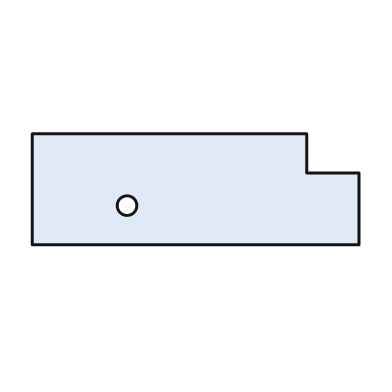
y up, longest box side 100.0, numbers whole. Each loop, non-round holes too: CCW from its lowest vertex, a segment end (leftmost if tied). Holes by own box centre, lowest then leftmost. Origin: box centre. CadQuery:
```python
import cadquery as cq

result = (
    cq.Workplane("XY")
    .moveTo(-50.0, -17.0)
    .lineTo(50.0, -17.0)
    .lineTo(50.0, 5.0)
    .lineTo(34.0, 5.0)
    .lineTo(34.0, 17.0)
    .lineTo(-50.0, 17.0)
    .close()
    .moveTo(-21.0, -5.0)
    .circle(3.0)
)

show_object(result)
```